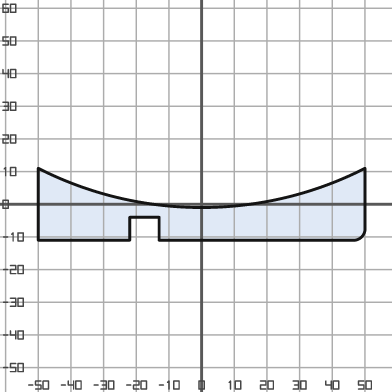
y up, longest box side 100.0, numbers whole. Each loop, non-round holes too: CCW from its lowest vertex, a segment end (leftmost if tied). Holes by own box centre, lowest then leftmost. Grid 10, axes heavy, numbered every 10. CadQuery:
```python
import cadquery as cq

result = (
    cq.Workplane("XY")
    .moveTo(-50.0, -11.0)
    .lineTo(-22.0, -11.0)
    .lineTo(-22.0, -4.0)
    .lineTo(-13.0, -4.0)
    .lineTo(-13.0, -11.0)
    .lineTo(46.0, -11.0)
    .threePointArc((49.0, -10.0), (50.0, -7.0))
    .lineTo(50.0, 11.0)
    .threePointArc((0.0, -1.0), (-50.0, 11.0))
    .close()
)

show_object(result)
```